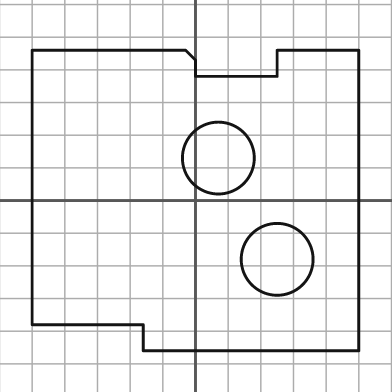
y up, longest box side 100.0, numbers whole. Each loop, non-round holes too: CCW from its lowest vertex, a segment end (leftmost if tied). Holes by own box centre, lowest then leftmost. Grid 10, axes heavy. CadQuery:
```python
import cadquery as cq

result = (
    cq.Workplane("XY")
    .moveTo(-16.0, -46.0)
    .lineTo(50.0, -46.0)
    .lineTo(50.0, 46.0)
    .lineTo(25.0, 46.0)
    .lineTo(25.0, 38.0)
    .lineTo(0.0, 38.0)
    .lineTo(0.0, 43.0)
    .lineTo(-3.0, 46.0)
    .lineTo(-50.0, 46.0)
    .lineTo(-50.0, -38.0)
    .lineTo(-16.0, -38.0)
    .close()
    .moveTo(25.0, -18.0)
    .circle(11.0)
    .moveTo(7.0, 13.0)
    .circle(11.0)
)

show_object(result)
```